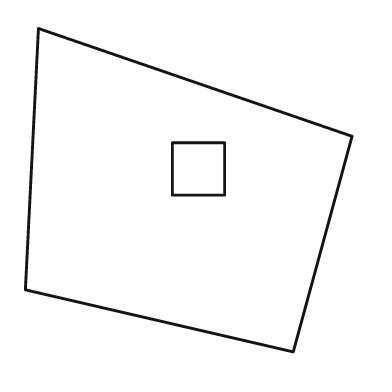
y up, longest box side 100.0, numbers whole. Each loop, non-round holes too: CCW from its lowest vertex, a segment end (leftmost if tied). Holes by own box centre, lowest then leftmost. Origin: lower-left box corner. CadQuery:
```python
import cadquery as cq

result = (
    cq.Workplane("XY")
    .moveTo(82.0, 0.0)
    .lineTo(100.0, 66.0)
    .lineTo(4.0, 99.0)
    .lineTo(0.0, 19.0)
    .close()
    .moveTo(45.0, 48.0)
    .lineTo(61.0, 48.0)
    .lineTo(61.0, 64.0)
    .lineTo(45.0, 64.0)
    .close()
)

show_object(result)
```